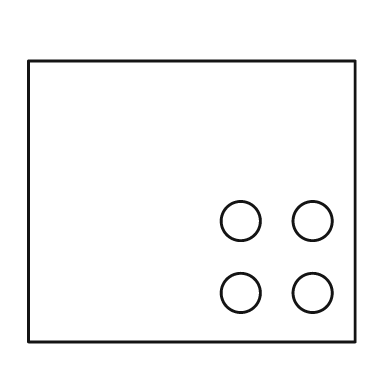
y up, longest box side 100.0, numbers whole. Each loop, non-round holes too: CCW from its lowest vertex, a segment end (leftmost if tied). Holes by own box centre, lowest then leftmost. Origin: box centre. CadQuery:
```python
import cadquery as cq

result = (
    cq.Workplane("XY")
    .moveTo(-50.0, -43.0)
    .lineTo(50.0, -43.0)
    .lineTo(50.0, 43.0)
    .lineTo(-50.0, 43.0)
    .close()
    .moveTo(15.0, -28.0)
    .circle(6.0)
    .moveTo(37.0, -28.0)
    .circle(6.0)
    .moveTo(15.0, -6.0)
    .circle(6.0)
    .moveTo(37.0, -6.0)
    .circle(6.0)
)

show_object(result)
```